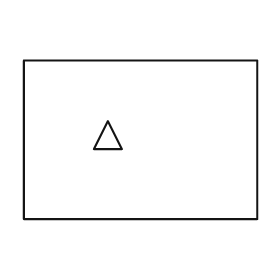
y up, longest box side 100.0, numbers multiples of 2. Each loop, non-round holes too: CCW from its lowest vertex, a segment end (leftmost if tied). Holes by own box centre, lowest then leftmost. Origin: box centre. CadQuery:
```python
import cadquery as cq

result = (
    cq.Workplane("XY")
    .moveTo(-50.0, -34.0)
    .lineTo(50.0, -34.0)
    .lineTo(50.0, 34.0)
    .lineTo(-50.0, 34.0)
    .close()
    .moveTo(-20.0, -4.0)
    .lineTo(-8.0, -4.0)
    .lineTo(-14.0, 8.0)
    .close()
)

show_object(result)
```